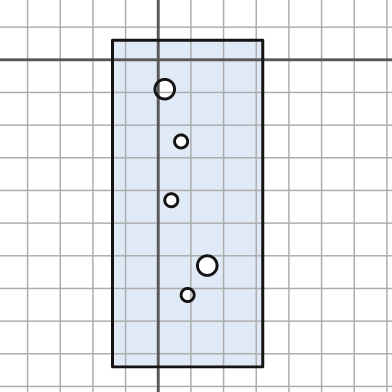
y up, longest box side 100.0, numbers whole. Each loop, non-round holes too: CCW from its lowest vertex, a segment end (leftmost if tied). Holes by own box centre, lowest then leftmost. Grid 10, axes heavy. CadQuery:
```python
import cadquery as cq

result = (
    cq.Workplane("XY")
    .moveTo(-14.0, -94.0)
    .lineTo(32.0, -94.0)
    .lineTo(32.0, 6.0)
    .lineTo(-14.0, 6.0)
    .close()
    .moveTo(9.0, -72.0)
    .circle(2.0)
    .moveTo(15.0, -63.0)
    .circle(3.0)
    .moveTo(4.0, -43.0)
    .circle(2.0)
    .moveTo(7.0, -25.0)
    .circle(2.0)
    .moveTo(2.0, -9.0)
    .circle(3.0)
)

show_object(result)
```